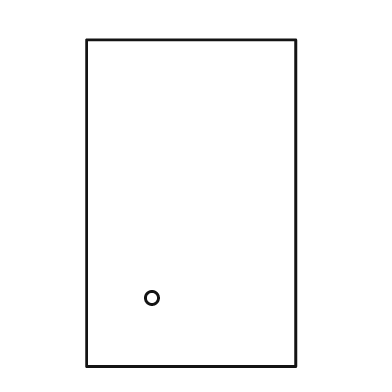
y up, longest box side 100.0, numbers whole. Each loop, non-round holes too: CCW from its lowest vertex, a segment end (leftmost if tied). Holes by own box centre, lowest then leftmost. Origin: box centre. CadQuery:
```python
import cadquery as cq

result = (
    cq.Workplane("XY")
    .moveTo(-32.0, -50.0)
    .lineTo(32.0, -50.0)
    .lineTo(32.0, 50.0)
    .lineTo(-32.0, 50.0)
    .close()
    .moveTo(-12.0, -29.0)
    .circle(2.0)
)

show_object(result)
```